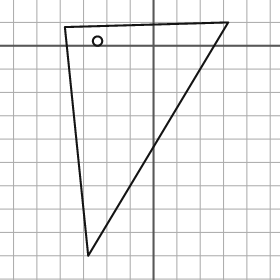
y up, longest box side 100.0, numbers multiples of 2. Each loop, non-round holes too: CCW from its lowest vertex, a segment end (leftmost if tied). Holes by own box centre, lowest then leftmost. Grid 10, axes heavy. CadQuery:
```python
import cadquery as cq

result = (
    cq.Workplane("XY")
    .moveTo(-28.0, -90.0)
    .lineTo(32.0, 10.0)
    .lineTo(-38.0, 8.0)
    .close()
    .moveTo(-24.0, 2.0)
    .circle(2.0)
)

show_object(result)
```